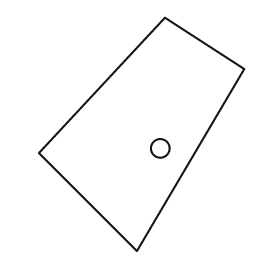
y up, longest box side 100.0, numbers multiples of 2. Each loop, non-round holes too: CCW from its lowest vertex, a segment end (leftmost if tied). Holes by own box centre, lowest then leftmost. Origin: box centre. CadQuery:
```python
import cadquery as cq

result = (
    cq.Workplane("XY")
    .moveTo(-2.0, -50.0)
    .lineTo(44.0, 28.0)
    .lineTo(10.0, 50.0)
    .lineTo(-44.0, -8.0)
    .close()
    .moveTo(8.0, -6.0)
    .circle(4.0)
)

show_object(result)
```